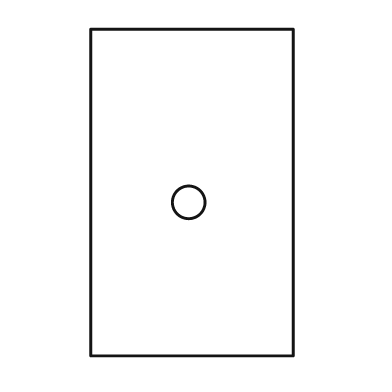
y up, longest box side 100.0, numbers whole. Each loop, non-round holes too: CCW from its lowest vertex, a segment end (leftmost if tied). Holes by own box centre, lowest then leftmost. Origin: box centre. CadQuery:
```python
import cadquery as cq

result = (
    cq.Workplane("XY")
    .moveTo(-31.0, -50.0)
    .lineTo(31.0, -50.0)
    .lineTo(31.0, 50.0)
    .lineTo(-31.0, 50.0)
    .close()
    .moveTo(-1.0, -3.0)
    .circle(5.0)
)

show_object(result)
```